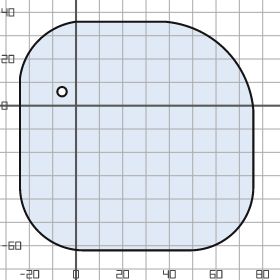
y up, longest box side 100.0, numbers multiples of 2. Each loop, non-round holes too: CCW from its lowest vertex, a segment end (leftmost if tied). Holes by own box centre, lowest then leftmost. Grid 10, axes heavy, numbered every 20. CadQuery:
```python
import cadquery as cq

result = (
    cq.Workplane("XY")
    .moveTo(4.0, -62.0)
    .lineTo(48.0, -62.0)
    .threePointArc((68.0, -54.0), (76.0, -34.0))
    .lineTo(76.0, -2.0)
    .threePointArc((64.0, 24.0), (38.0, 36.0))
    .lineTo(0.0, 36.0)
    .threePointArc((-16.0, 28.0), (-24.0, 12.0))
    .lineTo(-24.0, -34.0)
    .threePointArc((-16.0, -54.0), (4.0, -62.0))
    .close()
    .moveTo(-6.0, 6.0)
    .circle(2.0)
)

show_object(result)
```